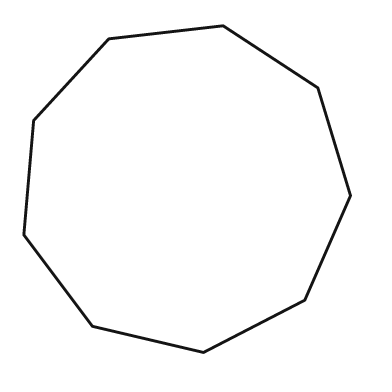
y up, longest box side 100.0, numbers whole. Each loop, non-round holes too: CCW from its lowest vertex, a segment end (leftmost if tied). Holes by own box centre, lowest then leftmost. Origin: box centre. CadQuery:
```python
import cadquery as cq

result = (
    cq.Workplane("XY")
    .moveTo(5.0, -50.0)
    .lineTo(36.0, -34.0)
    .lineTo(50.0, -2.0)
    .lineTo(40.0, 31.0)
    .lineTo(11.0, 50.0)
    .lineTo(-24.0, 46.0)
    .lineTo(-47.0, 21.0)
    .lineTo(-50.0, -14.0)
    .lineTo(-29.0, -42.0)
    .close()
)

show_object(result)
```